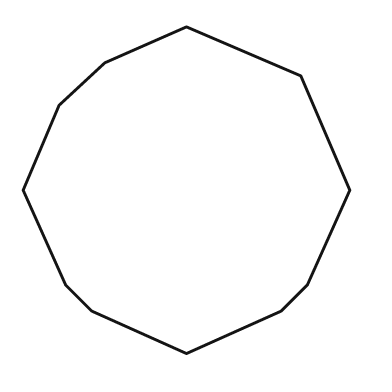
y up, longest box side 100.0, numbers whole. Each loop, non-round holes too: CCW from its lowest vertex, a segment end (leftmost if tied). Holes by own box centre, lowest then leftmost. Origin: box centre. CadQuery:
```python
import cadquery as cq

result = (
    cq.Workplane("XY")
    .moveTo(0.0, -50.0)
    .lineTo(29.0, -37.0)
    .lineTo(37.0, -29.0)
    .lineTo(50.0, 0.0)
    .lineTo(35.0, 35.0)
    .lineTo(0.0, 50.0)
    .lineTo(-25.0, 39.0)
    .lineTo(-39.0, 26.0)
    .lineTo(-50.0, 0.0)
    .lineTo(-37.0, -29.0)
    .lineTo(-29.0, -37.0)
    .close()
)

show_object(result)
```